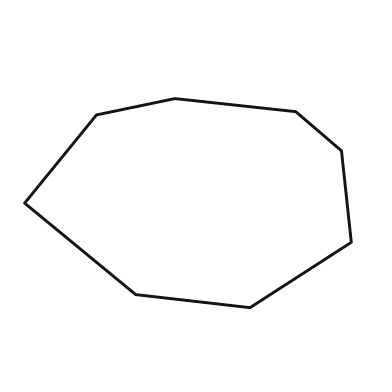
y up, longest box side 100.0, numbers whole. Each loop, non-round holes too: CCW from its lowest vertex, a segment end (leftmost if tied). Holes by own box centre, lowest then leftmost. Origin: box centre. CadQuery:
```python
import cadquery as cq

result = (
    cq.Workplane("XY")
    .moveTo(19.0, -32.0)
    .lineTo(50.0, -12.0)
    .lineTo(47.0, 16.0)
    .lineTo(33.0, 28.0)
    .lineTo(-4.0, 32.0)
    .lineTo(-28.0, 27.0)
    .lineTo(-50.0, 0.0)
    .lineTo(-16.0, -28.0)
    .close()
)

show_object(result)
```